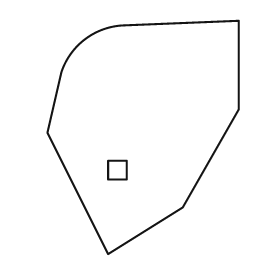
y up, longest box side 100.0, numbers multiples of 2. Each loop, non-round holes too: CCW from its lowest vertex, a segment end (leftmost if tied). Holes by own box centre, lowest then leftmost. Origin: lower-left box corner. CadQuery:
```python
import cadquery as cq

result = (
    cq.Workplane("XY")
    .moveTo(26.0, 0.0)
    .lineTo(58.0, 20.0)
    .lineTo(82.0, 62.0)
    .lineTo(82.0, 100.0)
    .lineTo(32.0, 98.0)
    .threePointArc((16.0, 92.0), (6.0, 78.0))
    .lineTo(0.0, 52.0)
    .close()
    .moveTo(26.0, 32.0)
    .lineTo(34.0, 32.0)
    .lineTo(34.0, 40.0)
    .lineTo(26.0, 40.0)
    .close()
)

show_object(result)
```